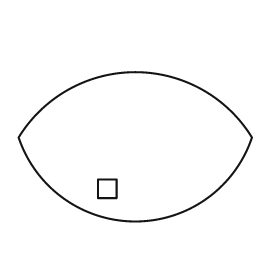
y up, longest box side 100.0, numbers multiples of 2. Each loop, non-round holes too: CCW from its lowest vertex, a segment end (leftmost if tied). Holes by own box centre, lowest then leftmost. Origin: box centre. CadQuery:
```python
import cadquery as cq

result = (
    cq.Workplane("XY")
    .moveTo(-50.0, 4.0)
    .threePointArc((0.0, -32.0), (50.0, 4.0))
    .threePointArc((0.0, 32.0), (-50.0, 4.0))
    .close()
    .moveTo(-16.0, -22.0)
    .lineTo(-8.0, -22.0)
    .lineTo(-8.0, -14.0)
    .lineTo(-16.0, -14.0)
    .close()
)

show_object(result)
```